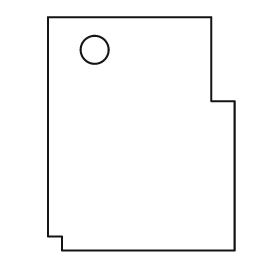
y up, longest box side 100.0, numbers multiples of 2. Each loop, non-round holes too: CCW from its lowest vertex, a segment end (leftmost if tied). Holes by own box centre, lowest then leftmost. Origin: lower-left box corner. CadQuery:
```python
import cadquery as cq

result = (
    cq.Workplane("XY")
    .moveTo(6.0, 0.0)
    .lineTo(80.0, 0.0)
    .lineTo(80.0, 64.0)
    .lineTo(70.0, 64.0)
    .lineTo(70.0, 100.0)
    .lineTo(0.0, 100.0)
    .lineTo(0.0, 6.0)
    .lineTo(6.0, 6.0)
    .close()
    .moveTo(20.0, 86.0)
    .circle(6.0)
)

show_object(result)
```